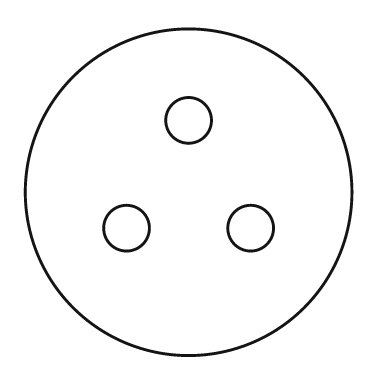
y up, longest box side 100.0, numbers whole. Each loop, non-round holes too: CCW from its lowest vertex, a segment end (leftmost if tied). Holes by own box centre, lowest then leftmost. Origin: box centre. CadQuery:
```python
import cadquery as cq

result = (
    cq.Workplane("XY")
    .moveTo(0.0, 0.0)
    .circle(50.0)
    .moveTo(-19.0, -11.0)
    .circle(7.0)
    .moveTo(19.0, -11.0)
    .circle(7.0)
    .moveTo(0.0, 22.0)
    .circle(7.0)
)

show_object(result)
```